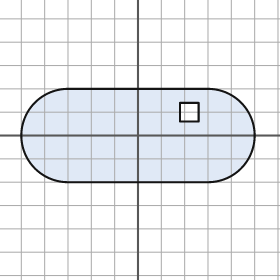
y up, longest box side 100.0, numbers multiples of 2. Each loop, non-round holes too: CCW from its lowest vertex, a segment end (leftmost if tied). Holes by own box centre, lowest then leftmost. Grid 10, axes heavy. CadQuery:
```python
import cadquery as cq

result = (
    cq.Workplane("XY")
    .moveTo(-30.0, -20.0)
    .lineTo(30.0, -20.0)
    .threePointArc((50.0, 0.0), (30.0, 20.0))
    .lineTo(-30.0, 20.0)
    .threePointArc((-50.0, 0.0), (-30.0, -20.0))
    .close()
    .moveTo(18.0, 6.0)
    .lineTo(26.0, 6.0)
    .lineTo(26.0, 14.0)
    .lineTo(18.0, 14.0)
    .close()
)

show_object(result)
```